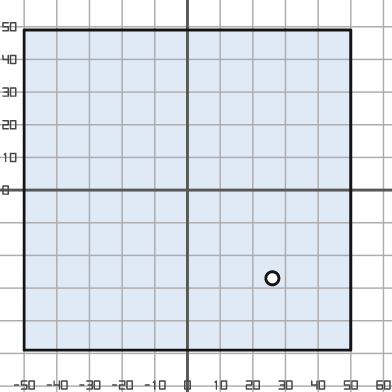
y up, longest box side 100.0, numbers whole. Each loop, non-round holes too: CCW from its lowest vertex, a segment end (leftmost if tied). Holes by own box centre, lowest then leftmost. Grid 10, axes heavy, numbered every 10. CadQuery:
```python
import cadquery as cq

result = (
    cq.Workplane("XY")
    .moveTo(-50.0, -49.0)
    .lineTo(50.0, -49.0)
    .lineTo(50.0, 49.0)
    .lineTo(-50.0, 49.0)
    .close()
    .moveTo(26.0, -27.0)
    .circle(2.0)
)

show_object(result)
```